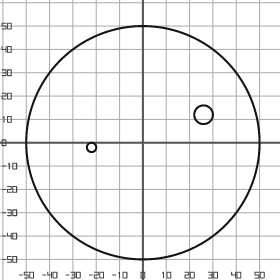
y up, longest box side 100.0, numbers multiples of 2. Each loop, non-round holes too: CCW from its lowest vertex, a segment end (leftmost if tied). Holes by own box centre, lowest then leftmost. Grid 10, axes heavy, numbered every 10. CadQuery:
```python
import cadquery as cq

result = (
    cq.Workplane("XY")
    .moveTo(0.0, 0.0)
    .circle(50.0)
    .moveTo(-22.0, -2.0)
    .circle(2.0)
    .moveTo(26.0, 12.0)
    .circle(4.0)
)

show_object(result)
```